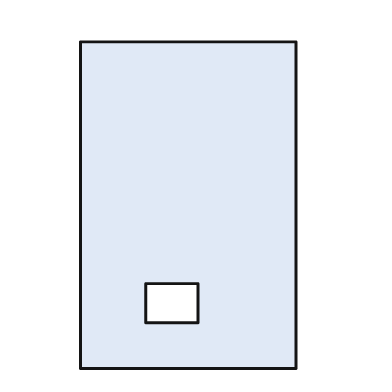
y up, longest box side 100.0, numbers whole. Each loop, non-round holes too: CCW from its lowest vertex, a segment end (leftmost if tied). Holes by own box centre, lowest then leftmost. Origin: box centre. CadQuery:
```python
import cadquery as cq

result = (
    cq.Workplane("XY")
    .moveTo(-33.0, -50.0)
    .lineTo(33.0, -50.0)
    .lineTo(33.0, 50.0)
    .lineTo(-33.0, 50.0)
    .close()
    .moveTo(-13.0, -36.0)
    .lineTo(3.0, -36.0)
    .lineTo(3.0, -24.0)
    .lineTo(-13.0, -24.0)
    .close()
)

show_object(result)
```